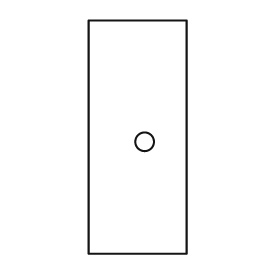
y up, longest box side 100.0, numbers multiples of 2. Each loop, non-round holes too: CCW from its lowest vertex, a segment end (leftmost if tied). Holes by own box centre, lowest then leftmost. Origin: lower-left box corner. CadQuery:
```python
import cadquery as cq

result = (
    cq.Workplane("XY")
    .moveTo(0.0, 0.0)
    .lineTo(42.0, 0.0)
    .lineTo(42.0, 100.0)
    .lineTo(0.0, 100.0)
    .close()
    .moveTo(24.0, 48.0)
    .circle(4.0)
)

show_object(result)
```